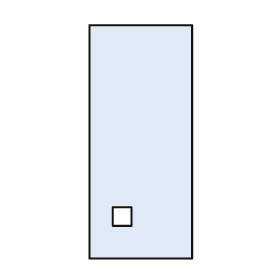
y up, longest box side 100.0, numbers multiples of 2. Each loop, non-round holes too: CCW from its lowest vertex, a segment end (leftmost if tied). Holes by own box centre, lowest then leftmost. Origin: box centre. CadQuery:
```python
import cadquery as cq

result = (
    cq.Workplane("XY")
    .moveTo(-22.0, -50.0)
    .lineTo(22.0, -50.0)
    .lineTo(22.0, 50.0)
    .lineTo(-22.0, 50.0)
    .close()
    .moveTo(-12.0, -36.0)
    .lineTo(-4.0, -36.0)
    .lineTo(-4.0, -28.0)
    .lineTo(-12.0, -28.0)
    .close()
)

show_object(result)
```